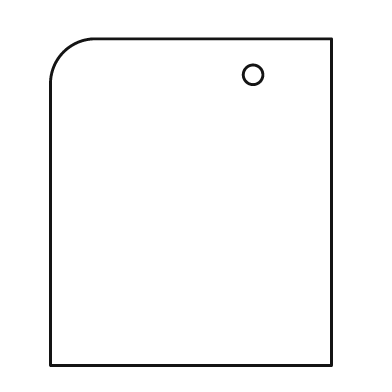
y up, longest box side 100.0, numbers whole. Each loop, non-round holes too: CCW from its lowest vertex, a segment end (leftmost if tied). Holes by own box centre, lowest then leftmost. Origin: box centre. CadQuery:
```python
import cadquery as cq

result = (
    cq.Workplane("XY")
    .moveTo(-43.0, -50.0)
    .lineTo(43.0, -50.0)
    .lineTo(43.0, 50.0)
    .lineTo(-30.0, 50.0)
    .threePointArc((-39.0, 46.0), (-43.0, 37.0))
    .close()
    .moveTo(19.0, 39.0)
    .circle(3.0)
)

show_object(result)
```